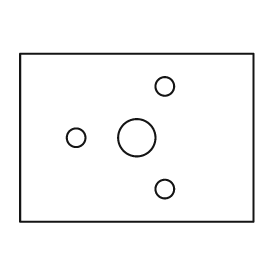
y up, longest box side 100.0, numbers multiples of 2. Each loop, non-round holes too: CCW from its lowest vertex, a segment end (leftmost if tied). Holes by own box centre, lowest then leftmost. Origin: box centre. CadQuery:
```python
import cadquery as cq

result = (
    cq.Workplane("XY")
    .moveTo(-50.0, -36.0)
    .lineTo(50.0, -36.0)
    .lineTo(50.0, 36.0)
    .lineTo(-50.0, 36.0)
    .close()
    .moveTo(12.0, -22.0)
    .circle(4.0)
    .moveTo(-26.0, 0.0)
    .circle(4.0)
    .moveTo(0.0, 0.0)
    .circle(8.0)
    .moveTo(12.0, 22.0)
    .circle(4.0)
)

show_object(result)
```